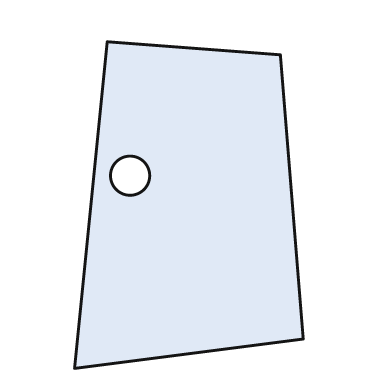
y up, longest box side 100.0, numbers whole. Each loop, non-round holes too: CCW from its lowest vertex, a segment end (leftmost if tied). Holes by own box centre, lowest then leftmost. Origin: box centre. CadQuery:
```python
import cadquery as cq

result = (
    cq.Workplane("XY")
    .moveTo(-35.0, -50.0)
    .lineTo(35.0, -41.0)
    .lineTo(28.0, 46.0)
    .lineTo(-25.0, 50.0)
    .close()
    .moveTo(-18.0, 9.0)
    .circle(6.0)
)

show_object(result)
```